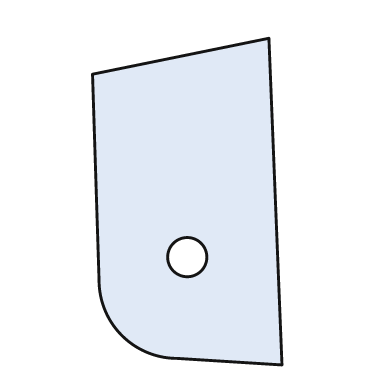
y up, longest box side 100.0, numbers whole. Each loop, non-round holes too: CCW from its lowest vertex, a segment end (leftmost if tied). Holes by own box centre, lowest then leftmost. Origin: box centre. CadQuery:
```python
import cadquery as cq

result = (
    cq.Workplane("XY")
    .moveTo(29.0, -50.0)
    .lineTo(25.0, 50.0)
    .lineTo(-29.0, 39.0)
    .lineTo(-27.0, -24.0)
    .threePointArc((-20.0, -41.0), (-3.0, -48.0))
    .close()
    .moveTo(0.0, -17.0)
    .circle(6.0)
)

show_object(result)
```